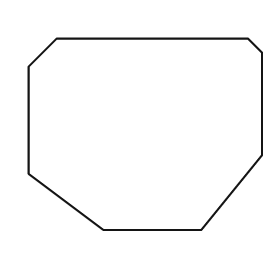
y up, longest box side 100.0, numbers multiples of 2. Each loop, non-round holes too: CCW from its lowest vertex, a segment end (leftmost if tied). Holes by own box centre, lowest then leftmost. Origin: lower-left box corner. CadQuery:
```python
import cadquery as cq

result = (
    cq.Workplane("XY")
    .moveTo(32.0, 0.0)
    .lineTo(74.0, 0.0)
    .lineTo(100.0, 32.0)
    .lineTo(100.0, 76.0)
    .lineTo(94.0, 82.0)
    .lineTo(12.0, 82.0)
    .lineTo(0.0, 70.0)
    .lineTo(0.0, 24.0)
    .close()
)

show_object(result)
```